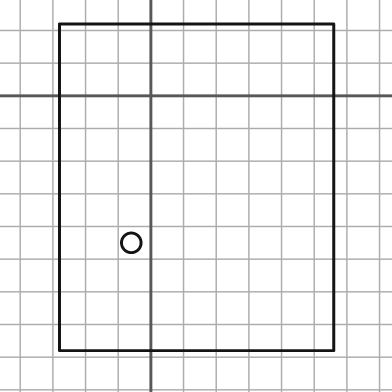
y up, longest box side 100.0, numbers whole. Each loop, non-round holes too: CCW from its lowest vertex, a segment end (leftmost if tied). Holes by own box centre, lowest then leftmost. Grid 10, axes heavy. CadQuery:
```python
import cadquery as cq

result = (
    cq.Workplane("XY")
    .moveTo(-28.0, -78.0)
    .lineTo(56.0, -78.0)
    .lineTo(56.0, 22.0)
    .lineTo(-28.0, 22.0)
    .close()
    .moveTo(-6.0, -45.0)
    .circle(3.0)
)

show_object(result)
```